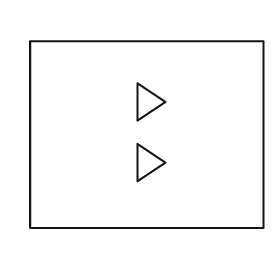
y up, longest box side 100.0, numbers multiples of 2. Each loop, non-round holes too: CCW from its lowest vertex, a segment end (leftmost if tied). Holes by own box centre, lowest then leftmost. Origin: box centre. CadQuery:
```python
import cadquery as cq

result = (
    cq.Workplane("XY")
    .moveTo(-50.0, -40.0)
    .lineTo(50.0, -40.0)
    .lineTo(50.0, 40.0)
    .lineTo(-50.0, 40.0)
    .close()
    .moveTo(-4.0, -20.0)
    .lineTo(8.0, -12.0)
    .lineTo(-4.0, -4.0)
    .close()
    .moveTo(-4.0, 6.0)
    .lineTo(8.0, 14.0)
    .lineTo(-4.0, 22.0)
    .close()
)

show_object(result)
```